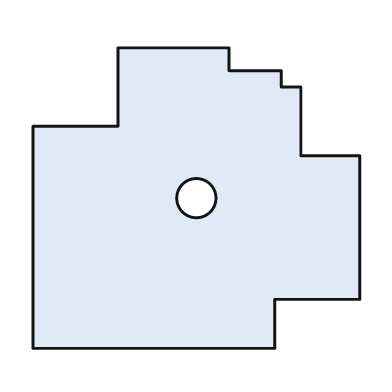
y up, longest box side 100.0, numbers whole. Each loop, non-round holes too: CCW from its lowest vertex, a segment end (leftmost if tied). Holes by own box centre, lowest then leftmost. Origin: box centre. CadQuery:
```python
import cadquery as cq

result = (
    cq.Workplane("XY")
    .moveTo(-50.0, -46.0)
    .lineTo(24.0, -46.0)
    .lineTo(24.0, -31.0)
    .lineTo(50.0, -31.0)
    .lineTo(50.0, 13.0)
    .lineTo(32.0, 13.0)
    .lineTo(32.0, 34.0)
    .lineTo(26.0, 34.0)
    .lineTo(26.0, 39.0)
    .lineTo(10.0, 39.0)
    .lineTo(10.0, 46.0)
    .lineTo(-24.0, 46.0)
    .lineTo(-24.0, 22.0)
    .lineTo(-50.0, 22.0)
    .close()
    .moveTo(0.0, 0.0)
    .circle(6.0)
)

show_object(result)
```